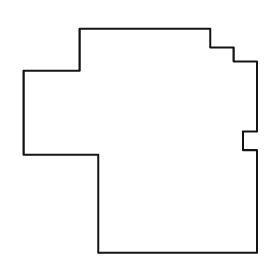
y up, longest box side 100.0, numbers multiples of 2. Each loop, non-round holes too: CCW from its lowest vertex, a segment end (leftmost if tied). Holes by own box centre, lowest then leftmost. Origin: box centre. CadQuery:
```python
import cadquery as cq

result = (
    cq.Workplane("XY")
    .moveTo(-18.0, -48.0)
    .lineTo(50.0, -48.0)
    .lineTo(50.0, -4.0)
    .lineTo(44.0, -4.0)
    .lineTo(44.0, 4.0)
    .lineTo(50.0, 4.0)
    .lineTo(50.0, 34.0)
    .lineTo(40.0, 34.0)
    .lineTo(40.0, 40.0)
    .lineTo(30.0, 40.0)
    .lineTo(30.0, 48.0)
    .lineTo(-26.0, 48.0)
    .lineTo(-26.0, 30.0)
    .lineTo(-50.0, 30.0)
    .lineTo(-50.0, -6.0)
    .lineTo(-18.0, -6.0)
    .close()
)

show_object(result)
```